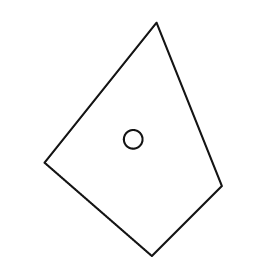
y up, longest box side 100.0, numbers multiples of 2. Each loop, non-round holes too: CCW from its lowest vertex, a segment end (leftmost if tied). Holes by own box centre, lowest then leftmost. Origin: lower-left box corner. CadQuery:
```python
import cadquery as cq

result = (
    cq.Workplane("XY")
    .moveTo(46.0, 0.0)
    .lineTo(76.0, 30.0)
    .lineTo(48.0, 100.0)
    .lineTo(0.0, 40.0)
    .close()
    .moveTo(38.0, 50.0)
    .circle(4.0)
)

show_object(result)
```